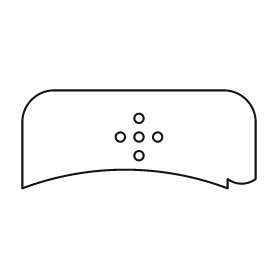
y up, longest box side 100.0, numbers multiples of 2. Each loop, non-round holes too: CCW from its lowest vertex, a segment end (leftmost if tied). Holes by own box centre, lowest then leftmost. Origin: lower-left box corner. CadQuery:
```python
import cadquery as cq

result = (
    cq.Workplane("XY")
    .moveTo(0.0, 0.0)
    .threePointArc((44.0, 8.0), (88.0, 0.0))
    .lineTo(88.0, 4.0)
    .threePointArc((94.0, 2.0), (100.0, 4.0))
    .lineTo(100.0, 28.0)
    .threePointArc((96.0, 38.0), (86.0, 42.0))
    .lineTo(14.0, 42.0)
    .threePointArc((4.0, 38.0), (0.0, 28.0))
    .close()
    .moveTo(50.0, 14.0)
    .circle(2.0)
    .moveTo(42.0, 22.0)
    .circle(2.0)
    .moveTo(50.0, 22.0)
    .circle(2.0)
    .moveTo(58.0, 22.0)
    .circle(2.0)
    .moveTo(50.0, 30.0)
    .circle(2.0)
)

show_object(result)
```